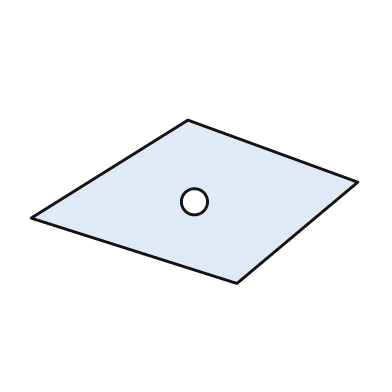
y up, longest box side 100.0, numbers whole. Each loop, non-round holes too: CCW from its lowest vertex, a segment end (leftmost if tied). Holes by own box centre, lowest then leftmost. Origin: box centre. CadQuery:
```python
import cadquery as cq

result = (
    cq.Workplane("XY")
    .moveTo(13.0, -25.0)
    .lineTo(50.0, 6.0)
    .lineTo(-2.0, 25.0)
    .lineTo(-50.0, -5.0)
    .close()
    .moveTo(0.0, 0.0)
    .circle(4.0)
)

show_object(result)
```